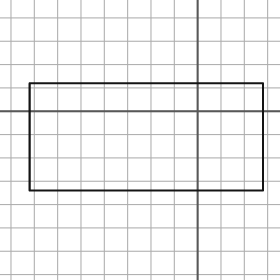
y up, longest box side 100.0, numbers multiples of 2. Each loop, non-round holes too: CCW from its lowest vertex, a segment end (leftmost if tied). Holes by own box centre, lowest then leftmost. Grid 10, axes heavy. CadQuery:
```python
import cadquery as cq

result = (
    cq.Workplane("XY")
    .moveTo(-72.0, -34.0)
    .lineTo(28.0, -34.0)
    .lineTo(28.0, 12.0)
    .lineTo(-72.0, 12.0)
    .close()
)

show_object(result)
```